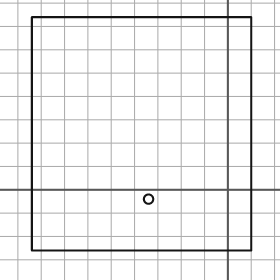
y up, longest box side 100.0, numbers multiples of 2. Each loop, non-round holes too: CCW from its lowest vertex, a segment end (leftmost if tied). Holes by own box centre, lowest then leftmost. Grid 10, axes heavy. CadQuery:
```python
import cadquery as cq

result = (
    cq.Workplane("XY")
    .moveTo(-84.0, -26.0)
    .lineTo(10.0, -26.0)
    .lineTo(10.0, 74.0)
    .lineTo(-84.0, 74.0)
    .close()
    .moveTo(-34.0, -4.0)
    .circle(2.0)
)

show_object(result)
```